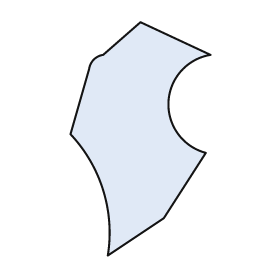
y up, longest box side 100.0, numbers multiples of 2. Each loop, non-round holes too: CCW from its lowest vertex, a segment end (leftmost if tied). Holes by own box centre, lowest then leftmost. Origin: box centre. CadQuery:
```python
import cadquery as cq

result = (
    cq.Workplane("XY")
    .moveTo(-14.0, -50.0)
    .lineTo(10.0, -34.0)
    .lineTo(28.0, -6.0)
    .threePointArc((12.0, 16.0), (30.0, 36.0))
    .lineTo(0.0, 50.0)
    .lineTo(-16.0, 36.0)
    .threePointArc((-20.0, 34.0), (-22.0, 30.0))
    .lineTo(-30.0, 2.0)
    .threePointArc((-16.0, -22.0), (-14.0, -50.0))
    .close()
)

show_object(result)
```